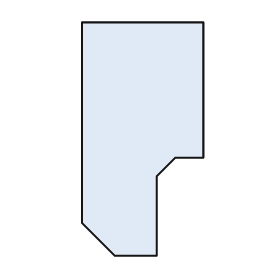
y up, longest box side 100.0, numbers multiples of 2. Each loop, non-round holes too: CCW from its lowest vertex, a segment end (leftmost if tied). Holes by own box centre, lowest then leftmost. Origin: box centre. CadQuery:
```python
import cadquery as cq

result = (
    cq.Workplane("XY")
    .moveTo(-12.0, -50.0)
    .lineTo(6.0, -50.0)
    .lineTo(6.0, -16.0)
    .lineTo(14.0, -8.0)
    .lineTo(26.0, -8.0)
    .lineTo(26.0, 50.0)
    .lineTo(-26.0, 50.0)
    .lineTo(-26.0, -36.0)
    .close()
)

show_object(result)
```